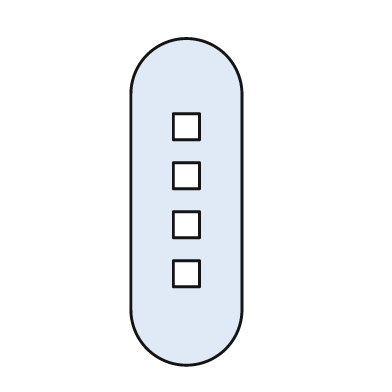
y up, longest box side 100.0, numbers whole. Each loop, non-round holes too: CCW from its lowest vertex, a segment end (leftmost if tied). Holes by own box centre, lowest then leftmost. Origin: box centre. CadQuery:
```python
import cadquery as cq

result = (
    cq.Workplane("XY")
    .moveTo(-17.0, -33.0)
    .threePointArc((0.0, -50.0), (17.0, -33.0))
    .lineTo(17.0, 33.0)
    .threePointArc((0.0, 50.0), (-17.0, 33.0))
    .close()
    .moveTo(-4.0, -26.0)
    .lineTo(4.0, -26.0)
    .lineTo(4.0, -18.0)
    .lineTo(-4.0, -18.0)
    .close()
    .moveTo(-4.0, -11.0)
    .lineTo(4.0, -11.0)
    .lineTo(4.0, -3.0)
    .lineTo(-4.0, -3.0)
    .close()
    .moveTo(-4.0, 4.0)
    .lineTo(4.0, 4.0)
    .lineTo(4.0, 12.0)
    .lineTo(-4.0, 12.0)
    .close()
    .moveTo(-4.0, 19.0)
    .lineTo(4.0, 19.0)
    .lineTo(4.0, 27.0)
    .lineTo(-4.0, 27.0)
    .close()
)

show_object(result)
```